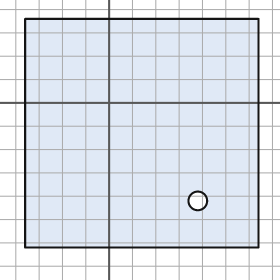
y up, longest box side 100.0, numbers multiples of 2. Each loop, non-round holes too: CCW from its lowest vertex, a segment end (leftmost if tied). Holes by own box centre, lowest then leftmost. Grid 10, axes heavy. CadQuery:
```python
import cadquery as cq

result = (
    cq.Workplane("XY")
    .moveTo(-36.0, -62.0)
    .lineTo(64.0, -62.0)
    .lineTo(64.0, 36.0)
    .lineTo(-36.0, 36.0)
    .close()
    .moveTo(38.0, -42.0)
    .circle(4.0)
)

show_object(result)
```